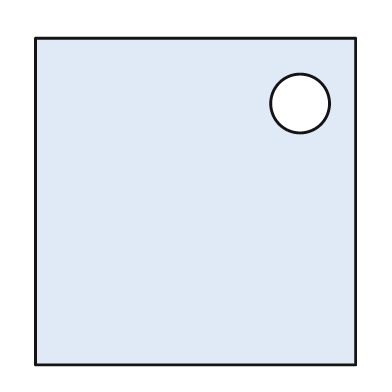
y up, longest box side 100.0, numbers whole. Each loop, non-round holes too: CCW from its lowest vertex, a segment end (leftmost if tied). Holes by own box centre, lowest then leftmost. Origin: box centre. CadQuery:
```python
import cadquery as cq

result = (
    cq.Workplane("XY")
    .moveTo(-49.0, -50.0)
    .lineTo(49.0, -50.0)
    .lineTo(49.0, 50.0)
    .lineTo(-49.0, 50.0)
    .close()
    .moveTo(32.0, 30.0)
    .circle(9.0)
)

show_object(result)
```